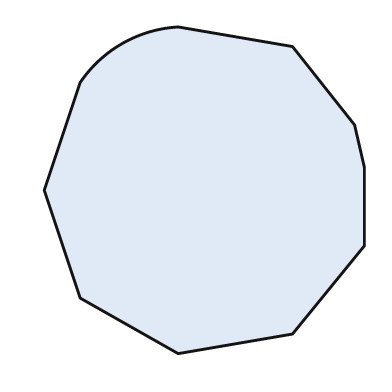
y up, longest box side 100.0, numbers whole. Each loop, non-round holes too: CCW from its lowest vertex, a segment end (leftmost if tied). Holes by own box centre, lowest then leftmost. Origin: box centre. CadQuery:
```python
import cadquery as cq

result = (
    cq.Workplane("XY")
    .moveTo(-8.0, -50.0)
    .lineTo(27.0, -44.0)
    .lineTo(49.0, -17.0)
    .lineTo(49.0, 7.0)
    .lineTo(46.0, 20.0)
    .lineTo(27.0, 44.0)
    .lineTo(-8.0, 50.0)
    .threePointArc((-25.0, 45.0), (-38.0, 33.0))
    .lineTo(-49.0, 0.0)
    .lineTo(-38.0, -33.0)
    .close()
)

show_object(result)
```